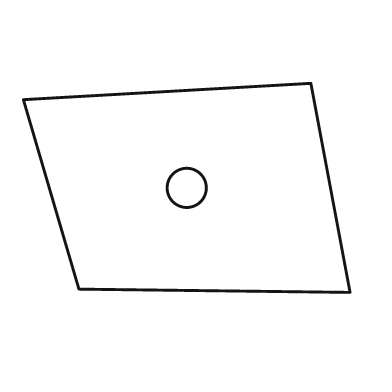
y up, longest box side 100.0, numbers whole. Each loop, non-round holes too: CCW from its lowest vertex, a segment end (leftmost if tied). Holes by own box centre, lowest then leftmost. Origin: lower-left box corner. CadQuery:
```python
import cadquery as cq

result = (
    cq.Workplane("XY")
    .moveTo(100.0, 0.0)
    .lineTo(88.0, 64.0)
    .lineTo(0.0, 59.0)
    .lineTo(17.0, 1.0)
    .close()
    .moveTo(50.0, 32.0)
    .circle(6.0)
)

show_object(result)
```